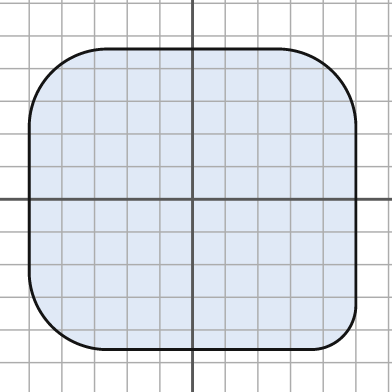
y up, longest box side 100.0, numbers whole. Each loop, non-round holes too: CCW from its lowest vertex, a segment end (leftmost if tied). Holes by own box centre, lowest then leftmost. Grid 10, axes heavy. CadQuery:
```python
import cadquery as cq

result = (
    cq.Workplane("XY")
    .moveTo(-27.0, -46.0)
    .lineTo(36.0, -46.0)
    .threePointArc((46.0, -42.0), (50.0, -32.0))
    .lineTo(50.0, 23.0)
    .threePointArc((43.0, 39.0), (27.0, 46.0))
    .lineTo(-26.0, 46.0)
    .threePointArc((-43.0, 39.0), (-50.0, 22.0))
    .lineTo(-50.0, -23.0)
    .threePointArc((-43.0, -39.0), (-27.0, -46.0))
    .close()
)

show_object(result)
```